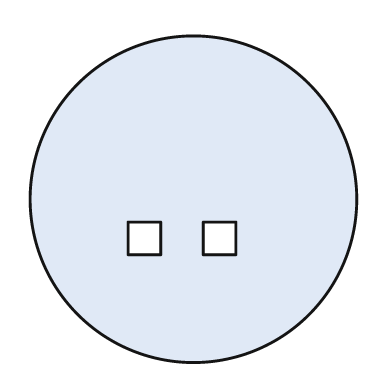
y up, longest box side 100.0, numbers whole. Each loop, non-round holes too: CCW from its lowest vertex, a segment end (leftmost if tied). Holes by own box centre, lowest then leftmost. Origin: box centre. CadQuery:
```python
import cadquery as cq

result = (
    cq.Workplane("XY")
    .moveTo(0.0, 0.0)
    .circle(50.0)
    .moveTo(-20.0, -17.0)
    .lineTo(-10.0, -17.0)
    .lineTo(-10.0, -7.0)
    .lineTo(-20.0, -7.0)
    .close()
    .moveTo(3.0, -17.0)
    .lineTo(13.0, -17.0)
    .lineTo(13.0, -7.0)
    .lineTo(3.0, -7.0)
    .close()
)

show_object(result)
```